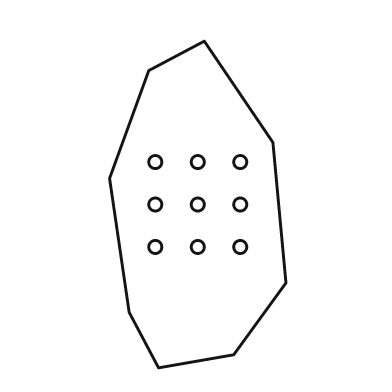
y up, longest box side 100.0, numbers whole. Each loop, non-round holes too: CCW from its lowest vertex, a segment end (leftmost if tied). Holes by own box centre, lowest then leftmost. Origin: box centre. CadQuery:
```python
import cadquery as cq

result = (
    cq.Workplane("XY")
    .moveTo(-12.0, -50.0)
    .lineTo(11.0, -46.0)
    .lineTo(27.0, -24.0)
    .lineTo(23.0, 19.0)
    .lineTo(2.0, 50.0)
    .lineTo(-15.0, 41.0)
    .lineTo(-27.0, 8.0)
    .lineTo(-21.0, -33.0)
    .close()
    .moveTo(-13.0, -13.0)
    .circle(2.0)
    .moveTo(0.0, -13.0)
    .circle(2.0)
    .moveTo(13.0, -13.0)
    .circle(2.0)
    .moveTo(-13.0, 0.0)
    .circle(2.0)
    .moveTo(0.0, 0.0)
    .circle(2.0)
    .moveTo(13.0, 0.0)
    .circle(2.0)
    .moveTo(-13.0, 13.0)
    .circle(2.0)
    .moveTo(0.0, 13.0)
    .circle(2.0)
    .moveTo(13.0, 13.0)
    .circle(2.0)
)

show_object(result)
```